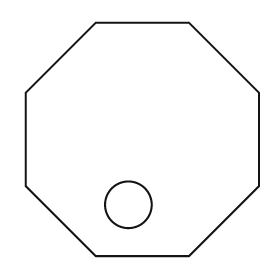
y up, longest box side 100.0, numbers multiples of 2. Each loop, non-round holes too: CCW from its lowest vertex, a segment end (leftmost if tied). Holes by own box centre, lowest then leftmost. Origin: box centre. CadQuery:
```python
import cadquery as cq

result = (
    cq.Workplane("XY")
    .moveTo(-20.0, -50.0)
    .lineTo(20.0, -50.0)
    .lineTo(50.0, -20.0)
    .lineTo(50.0, 20.0)
    .lineTo(20.0, 50.0)
    .lineTo(-20.0, 50.0)
    .lineTo(-50.0, 20.0)
    .lineTo(-50.0, -20.0)
    .close()
    .moveTo(-6.0, -28.0)
    .circle(10.0)
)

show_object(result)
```